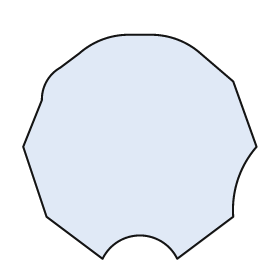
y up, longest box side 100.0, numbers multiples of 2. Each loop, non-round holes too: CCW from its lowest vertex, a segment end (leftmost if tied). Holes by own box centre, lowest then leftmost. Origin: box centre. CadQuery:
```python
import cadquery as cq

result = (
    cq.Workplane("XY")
    .moveTo(-16.0, -48.0)
    .threePointArc((0.0, -38.0), (16.0, -48.0))
    .lineTo(40.0, -30.0)
    .threePointArc((42.0, -14.0), (50.0, 0.0))
    .lineTo(40.0, 28.0)
    .lineTo(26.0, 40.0)
    .threePointArc((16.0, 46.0), (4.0, 48.0))
    .lineTo(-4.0, 48.0)
    .threePointArc((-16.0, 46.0), (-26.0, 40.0))
    .lineTo(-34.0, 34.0)
    .threePointArc((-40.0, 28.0), (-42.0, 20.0))
    .lineTo(-50.0, 0.0)
    .lineTo(-40.0, -30.0)
    .close()
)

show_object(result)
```